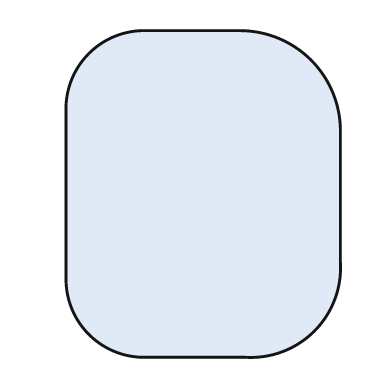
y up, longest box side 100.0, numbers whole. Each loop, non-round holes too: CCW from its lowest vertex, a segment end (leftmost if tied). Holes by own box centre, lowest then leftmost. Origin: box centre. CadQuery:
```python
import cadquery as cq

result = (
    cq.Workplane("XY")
    .moveTo(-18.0, -50.0)
    .lineTo(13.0, -50.0)
    .threePointArc((34.0, -42.0), (42.0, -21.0))
    .lineTo(42.0, 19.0)
    .threePointArc((33.0, 41.0), (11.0, 50.0))
    .lineTo(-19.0, 50.0)
    .threePointArc((-35.0, 43.0), (-42.0, 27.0))
    .lineTo(-42.0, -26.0)
    .threePointArc((-35.0, -43.0), (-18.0, -50.0))
    .close()
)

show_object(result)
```